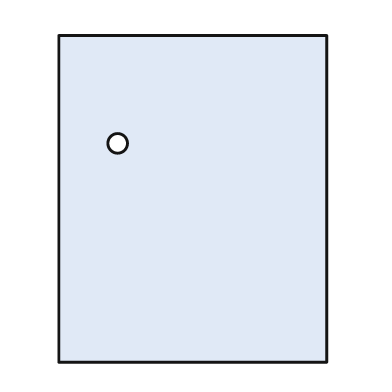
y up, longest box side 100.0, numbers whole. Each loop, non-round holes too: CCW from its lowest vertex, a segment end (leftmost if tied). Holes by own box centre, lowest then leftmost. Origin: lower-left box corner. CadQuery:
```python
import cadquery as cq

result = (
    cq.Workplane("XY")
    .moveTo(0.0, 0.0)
    .lineTo(82.0, 0.0)
    .lineTo(82.0, 100.0)
    .lineTo(0.0, 100.0)
    .close()
    .moveTo(18.0, 67.0)
    .circle(3.0)
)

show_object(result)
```